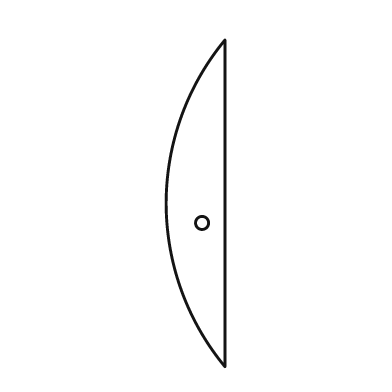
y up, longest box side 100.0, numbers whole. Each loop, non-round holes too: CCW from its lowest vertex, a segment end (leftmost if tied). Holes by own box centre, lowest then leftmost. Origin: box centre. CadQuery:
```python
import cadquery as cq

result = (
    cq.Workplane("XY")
    .moveTo(9.0, -50.0)
    .lineTo(9.0, 50.0)
    .threePointArc((-9.0, 0.0), (9.0, -50.0))
    .close()
    .moveTo(2.0, -6.0)
    .circle(2.0)
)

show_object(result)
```